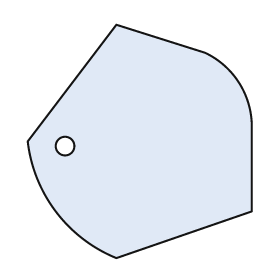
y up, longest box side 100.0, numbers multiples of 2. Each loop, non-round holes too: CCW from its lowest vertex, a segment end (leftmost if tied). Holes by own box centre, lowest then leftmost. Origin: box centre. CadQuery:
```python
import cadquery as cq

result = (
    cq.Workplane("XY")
    .moveTo(-10.0, -50.0)
    .lineTo(48.0, -30.0)
    .lineTo(48.0, 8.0)
    .threePointArc((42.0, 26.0), (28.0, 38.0))
    .lineTo(-10.0, 50.0)
    .lineTo(-48.0, 0.0)
    .threePointArc((-36.0, -30.0), (-10.0, -50.0))
    .close()
    .moveTo(-32.0, -2.0)
    .circle(4.0)
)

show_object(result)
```